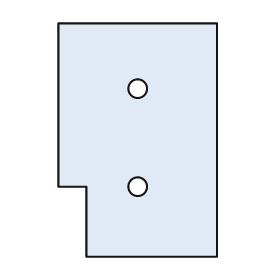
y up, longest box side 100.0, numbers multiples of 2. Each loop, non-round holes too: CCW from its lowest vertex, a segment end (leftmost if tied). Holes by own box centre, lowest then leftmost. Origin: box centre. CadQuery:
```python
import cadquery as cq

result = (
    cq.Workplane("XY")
    .moveTo(-22.0, -50.0)
    .lineTo(34.0, -50.0)
    .lineTo(34.0, 50.0)
    .lineTo(-34.0, 50.0)
    .lineTo(-34.0, -20.0)
    .lineTo(-22.0, -20.0)
    .close()
    .moveTo(0.0, -20.0)
    .circle(4.0)
    .moveTo(0.0, 22.0)
    .circle(4.0)
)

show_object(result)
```